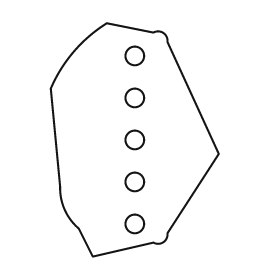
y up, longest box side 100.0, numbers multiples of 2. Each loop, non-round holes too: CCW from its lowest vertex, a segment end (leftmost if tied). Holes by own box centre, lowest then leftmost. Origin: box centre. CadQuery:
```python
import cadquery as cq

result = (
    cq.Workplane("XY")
    .moveTo(-18.0, -50.0)
    .lineTo(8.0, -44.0)
    .threePointArc((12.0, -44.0), (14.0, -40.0))
    .lineTo(36.0, -6.0)
    .lineTo(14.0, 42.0)
    .threePointArc((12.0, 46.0), (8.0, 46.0))
    .lineTo(-12.0, 50.0)
    .threePointArc((-26.0, 38.0), (-36.0, 22.0))
    .lineTo(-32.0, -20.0)
    .threePointArc((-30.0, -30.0), (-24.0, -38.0))
    .close()
    .moveTo(0.0, -36.0)
    .circle(4.0)
    .moveTo(0.0, -18.0)
    .circle(4.0)
    .moveTo(0.0, 0.0)
    .circle(4.0)
    .moveTo(0.0, 18.0)
    .circle(4.0)
    .moveTo(0.0, 36.0)
    .circle(4.0)
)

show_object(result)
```